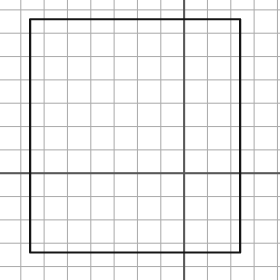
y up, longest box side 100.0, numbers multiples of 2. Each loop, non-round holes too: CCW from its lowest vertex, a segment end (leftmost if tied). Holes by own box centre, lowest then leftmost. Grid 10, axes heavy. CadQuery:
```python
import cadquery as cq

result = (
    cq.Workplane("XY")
    .moveTo(-66.0, -34.0)
    .lineTo(24.0, -34.0)
    .lineTo(24.0, 66.0)
    .lineTo(-66.0, 66.0)
    .close()
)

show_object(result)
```